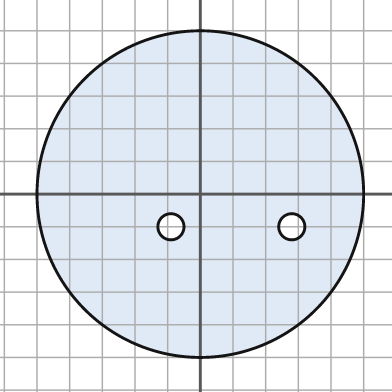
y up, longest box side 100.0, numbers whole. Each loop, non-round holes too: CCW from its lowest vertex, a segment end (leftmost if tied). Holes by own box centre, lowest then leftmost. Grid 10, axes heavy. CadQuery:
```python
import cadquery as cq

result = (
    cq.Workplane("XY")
    .moveTo(0.0, 0.0)
    .circle(50.0)
    .moveTo(-9.0, -10.0)
    .circle(4.0)
    .moveTo(28.0, -10.0)
    .circle(4.0)
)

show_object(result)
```